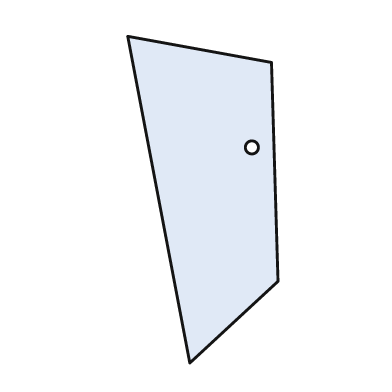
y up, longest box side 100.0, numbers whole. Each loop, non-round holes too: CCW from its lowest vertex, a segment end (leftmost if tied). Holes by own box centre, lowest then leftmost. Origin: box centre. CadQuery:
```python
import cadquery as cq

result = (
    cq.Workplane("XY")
    .moveTo(-4.0, -50.0)
    .lineTo(23.0, -25.0)
    .lineTo(21.0, 42.0)
    .lineTo(-23.0, 50.0)
    .close()
    .moveTo(15.0, 16.0)
    .circle(2.0)
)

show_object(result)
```